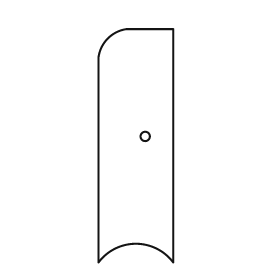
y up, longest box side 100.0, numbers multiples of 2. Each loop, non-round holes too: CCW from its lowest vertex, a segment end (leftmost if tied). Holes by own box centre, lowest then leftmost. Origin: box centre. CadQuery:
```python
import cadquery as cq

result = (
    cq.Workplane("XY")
    .moveTo(-16.0, -50.0)
    .threePointArc((0.0, -42.0), (16.0, -50.0))
    .lineTo(16.0, 50.0)
    .lineTo(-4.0, 50.0)
    .threePointArc((-12.0, 46.0), (-16.0, 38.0))
    .close()
    .moveTo(4.0, 4.0)
    .circle(2.0)
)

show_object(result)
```